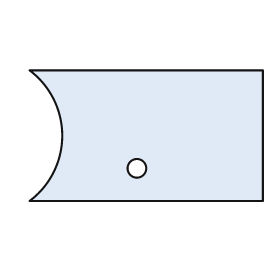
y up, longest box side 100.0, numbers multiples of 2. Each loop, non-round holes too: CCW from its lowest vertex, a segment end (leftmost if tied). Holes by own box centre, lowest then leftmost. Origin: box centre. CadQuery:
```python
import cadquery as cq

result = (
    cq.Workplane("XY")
    .moveTo(-50.0, -28.0)
    .lineTo(50.0, -28.0)
    .lineTo(50.0, 28.0)
    .lineTo(-50.0, 28.0)
    .threePointArc((-36.0, 0.0), (-50.0, -28.0))
    .close()
    .moveTo(-4.0, -14.0)
    .circle(4.0)
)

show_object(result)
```